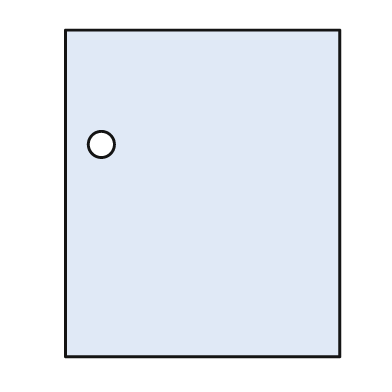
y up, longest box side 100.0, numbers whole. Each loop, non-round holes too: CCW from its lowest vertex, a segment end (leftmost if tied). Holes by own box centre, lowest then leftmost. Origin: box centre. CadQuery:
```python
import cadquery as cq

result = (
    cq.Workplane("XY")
    .moveTo(-42.0, -50.0)
    .lineTo(42.0, -50.0)
    .lineTo(42.0, 50.0)
    .lineTo(-42.0, 50.0)
    .close()
    .moveTo(-31.0, 15.0)
    .circle(4.0)
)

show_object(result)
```